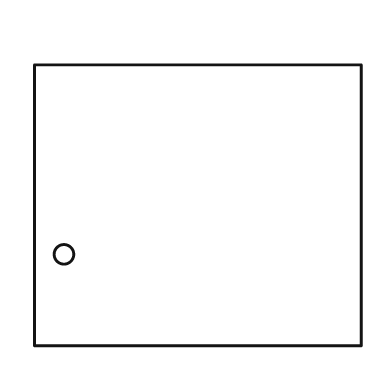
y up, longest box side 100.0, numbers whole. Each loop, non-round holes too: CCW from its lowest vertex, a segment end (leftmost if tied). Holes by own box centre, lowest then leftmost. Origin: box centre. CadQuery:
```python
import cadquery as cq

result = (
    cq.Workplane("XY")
    .moveTo(-50.0, -43.0)
    .lineTo(50.0, -43.0)
    .lineTo(50.0, 43.0)
    .lineTo(-50.0, 43.0)
    .close()
    .moveTo(-41.0, -15.0)
    .circle(3.0)
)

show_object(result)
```